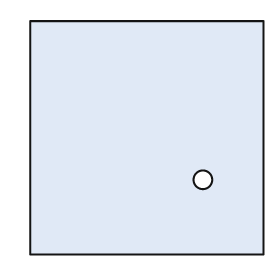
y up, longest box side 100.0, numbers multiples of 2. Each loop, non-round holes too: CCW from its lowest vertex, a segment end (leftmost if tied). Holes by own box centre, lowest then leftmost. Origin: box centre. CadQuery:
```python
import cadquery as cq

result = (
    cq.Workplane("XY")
    .moveTo(-50.0, -50.0)
    .lineTo(50.0, -50.0)
    .lineTo(50.0, 50.0)
    .lineTo(-50.0, 50.0)
    .close()
    .moveTo(24.0, -18.0)
    .circle(4.0)
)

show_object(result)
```